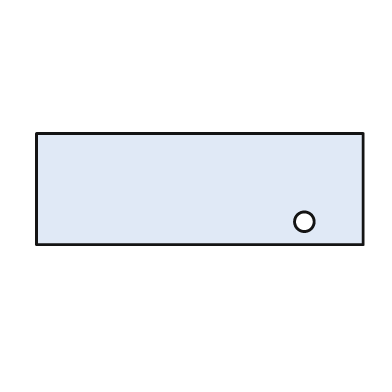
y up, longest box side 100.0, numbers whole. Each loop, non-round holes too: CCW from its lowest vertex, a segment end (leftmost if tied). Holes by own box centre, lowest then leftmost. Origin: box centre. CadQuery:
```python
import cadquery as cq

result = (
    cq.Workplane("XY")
    .moveTo(-50.0, -17.0)
    .lineTo(50.0, -17.0)
    .lineTo(50.0, 17.0)
    .lineTo(-50.0, 17.0)
    .close()
    .moveTo(32.0, -10.0)
    .circle(3.0)
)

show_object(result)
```